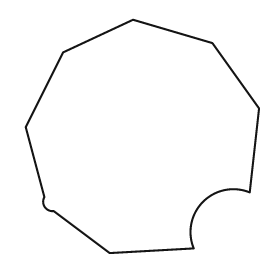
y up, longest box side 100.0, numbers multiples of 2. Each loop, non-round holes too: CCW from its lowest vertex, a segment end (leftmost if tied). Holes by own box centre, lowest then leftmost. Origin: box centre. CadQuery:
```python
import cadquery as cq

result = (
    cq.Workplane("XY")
    .moveTo(-14.0, -50.0)
    .lineTo(22.0, -48.0)
    .threePointArc((26.0, -28.0), (46.0, -24.0))
    .lineTo(50.0, 12.0)
    .lineTo(30.0, 40.0)
    .lineTo(-4.0, 50.0)
    .lineTo(-34.0, 36.0)
    .lineTo(-50.0, 4.0)
    .lineTo(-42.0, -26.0)
    .threePointArc((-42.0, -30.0), (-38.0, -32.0))
    .close()
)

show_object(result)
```